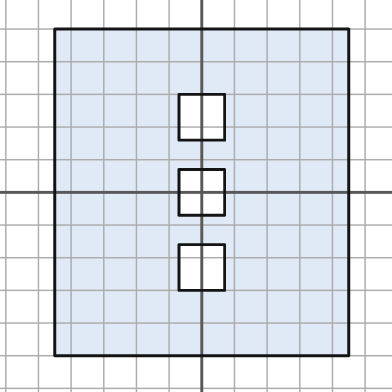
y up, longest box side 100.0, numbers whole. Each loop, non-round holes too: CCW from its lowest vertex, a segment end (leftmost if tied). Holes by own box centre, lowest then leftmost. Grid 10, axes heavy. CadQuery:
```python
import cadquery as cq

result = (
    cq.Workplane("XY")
    .moveTo(-45.0, -50.0)
    .lineTo(45.0, -50.0)
    .lineTo(45.0, 50.0)
    .lineTo(-45.0, 50.0)
    .close()
    .moveTo(-7.0, -30.0)
    .lineTo(7.0, -30.0)
    .lineTo(7.0, -16.0)
    .lineTo(-7.0, -16.0)
    .close()
    .moveTo(-7.0, -7.0)
    .lineTo(7.0, -7.0)
    .lineTo(7.0, 7.0)
    .lineTo(-7.0, 7.0)
    .close()
    .moveTo(-7.0, 16.0)
    .lineTo(7.0, 16.0)
    .lineTo(7.0, 30.0)
    .lineTo(-7.0, 30.0)
    .close()
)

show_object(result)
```